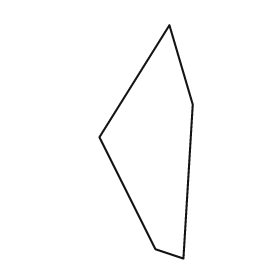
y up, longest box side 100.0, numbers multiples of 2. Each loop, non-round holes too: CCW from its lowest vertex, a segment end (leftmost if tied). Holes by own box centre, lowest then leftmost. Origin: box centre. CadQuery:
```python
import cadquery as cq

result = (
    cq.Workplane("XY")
    .moveTo(16.0, -50.0)
    .lineTo(20.0, 16.0)
    .lineTo(10.0, 50.0)
    .lineTo(-20.0, 2.0)
    .lineTo(4.0, -46.0)
    .close()
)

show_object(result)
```